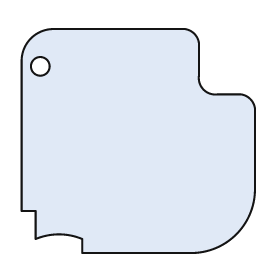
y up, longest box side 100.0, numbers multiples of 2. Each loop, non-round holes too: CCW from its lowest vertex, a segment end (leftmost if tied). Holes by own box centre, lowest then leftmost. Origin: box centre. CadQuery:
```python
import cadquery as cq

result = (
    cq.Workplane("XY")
    .moveTo(-24.0, -48.0)
    .lineTo(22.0, -48.0)
    .threePointArc((42.0, -40.0), (50.0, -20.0))
    .lineTo(50.0, 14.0)
    .threePointArc((48.0, 18.0), (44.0, 20.0))
    .lineTo(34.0, 20.0)
    .threePointArc((28.0, 22.0), (26.0, 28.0))
    .lineTo(26.0, 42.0)
    .threePointArc((24.0, 46.0), (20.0, 48.0))
    .lineTo(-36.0, 48.0)
    .threePointArc((-46.0, 44.0), (-50.0, 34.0))
    .lineTo(-50.0, -30.0)
    .lineTo(-44.0, -30.0)
    .lineTo(-44.0, -42.0)
    .threePointArc((-34.0, -40.0), (-24.0, -42.0))
    .close()
    .moveTo(-42.0, 32.0)
    .circle(4.0)
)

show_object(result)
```